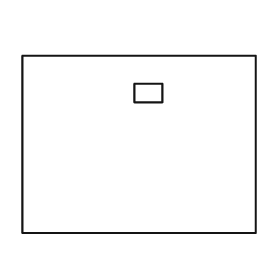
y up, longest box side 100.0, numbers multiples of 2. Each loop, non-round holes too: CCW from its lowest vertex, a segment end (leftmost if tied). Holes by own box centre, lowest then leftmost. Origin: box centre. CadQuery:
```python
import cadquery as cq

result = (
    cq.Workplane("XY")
    .moveTo(-50.0, -38.0)
    .lineTo(50.0, -38.0)
    .lineTo(50.0, 38.0)
    .lineTo(-50.0, 38.0)
    .close()
    .moveTo(-2.0, 18.0)
    .lineTo(10.0, 18.0)
    .lineTo(10.0, 26.0)
    .lineTo(-2.0, 26.0)
    .close()
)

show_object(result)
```